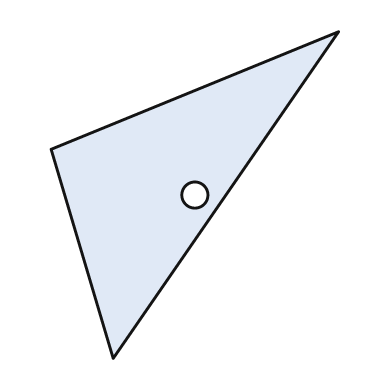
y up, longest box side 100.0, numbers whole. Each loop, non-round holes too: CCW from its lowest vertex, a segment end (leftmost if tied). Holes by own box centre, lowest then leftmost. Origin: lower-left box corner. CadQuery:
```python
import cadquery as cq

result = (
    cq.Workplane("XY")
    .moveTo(19.0, 0.0)
    .lineTo(88.0, 100.0)
    .lineTo(0.0, 64.0)
    .close()
    .moveTo(44.0, 50.0)
    .circle(4.0)
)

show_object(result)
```